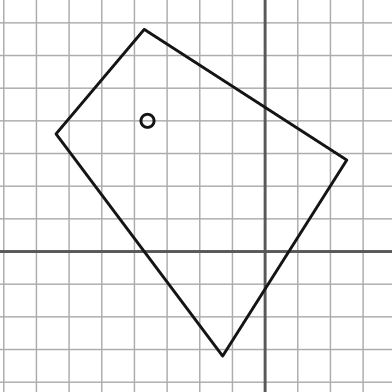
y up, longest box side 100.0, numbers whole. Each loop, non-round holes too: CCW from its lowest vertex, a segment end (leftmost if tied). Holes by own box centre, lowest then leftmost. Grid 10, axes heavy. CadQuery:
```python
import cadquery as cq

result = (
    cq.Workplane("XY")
    .moveTo(-13.0, -32.0)
    .lineTo(25.0, 28.0)
    .lineTo(-37.0, 68.0)
    .lineTo(-64.0, 36.0)
    .close()
    .moveTo(-36.0, 40.0)
    .circle(2.0)
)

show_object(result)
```